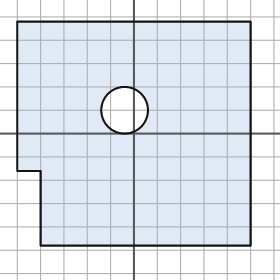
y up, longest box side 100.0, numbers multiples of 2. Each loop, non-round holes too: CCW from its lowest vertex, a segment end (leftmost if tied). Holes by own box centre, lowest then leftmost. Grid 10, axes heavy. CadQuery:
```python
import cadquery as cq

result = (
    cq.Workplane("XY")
    .moveTo(-40.0, -48.0)
    .lineTo(50.0, -48.0)
    .lineTo(50.0, 48.0)
    .lineTo(-50.0, 48.0)
    .lineTo(-50.0, -16.0)
    .lineTo(-40.0, -16.0)
    .close()
    .moveTo(-4.0, 10.0)
    .circle(10.0)
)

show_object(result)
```